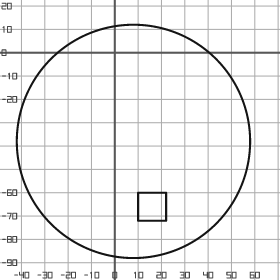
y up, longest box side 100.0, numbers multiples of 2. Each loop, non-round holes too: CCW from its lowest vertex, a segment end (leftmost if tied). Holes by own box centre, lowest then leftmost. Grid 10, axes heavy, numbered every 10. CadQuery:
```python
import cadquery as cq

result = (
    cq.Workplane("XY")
    .moveTo(8.0, -38.0)
    .circle(50.0)
    .moveTo(10.0, -72.0)
    .lineTo(22.0, -72.0)
    .lineTo(22.0, -60.0)
    .lineTo(10.0, -60.0)
    .close()
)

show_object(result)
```